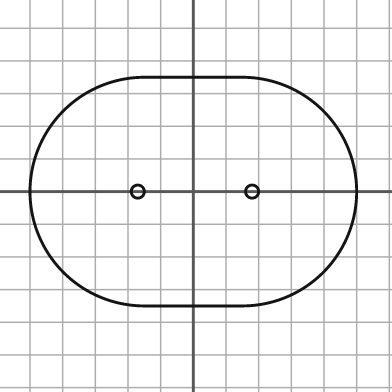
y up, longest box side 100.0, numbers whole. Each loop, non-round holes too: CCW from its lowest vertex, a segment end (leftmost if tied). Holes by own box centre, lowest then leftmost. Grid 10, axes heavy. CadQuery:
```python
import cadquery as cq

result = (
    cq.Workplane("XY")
    .moveTo(-15.0, -35.0)
    .lineTo(15.0, -35.0)
    .threePointArc((50.0, 0.0), (15.0, 35.0))
    .lineTo(-15.0, 35.0)
    .threePointArc((-50.0, 0.0), (-15.0, -35.0))
    .close()
    .moveTo(-17.0, 0.0)
    .circle(2.0)
    .moveTo(18.0, 0.0)
    .circle(2.0)
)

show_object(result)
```